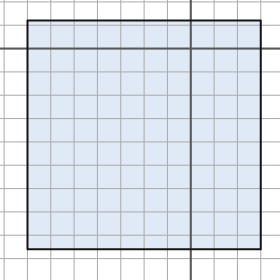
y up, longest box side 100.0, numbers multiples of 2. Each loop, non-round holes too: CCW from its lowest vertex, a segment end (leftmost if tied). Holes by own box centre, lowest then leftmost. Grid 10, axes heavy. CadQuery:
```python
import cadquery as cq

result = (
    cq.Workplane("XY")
    .moveTo(-70.0, -86.0)
    .lineTo(30.0, -86.0)
    .lineTo(30.0, 12.0)
    .lineTo(-70.0, 12.0)
    .close()
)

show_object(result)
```